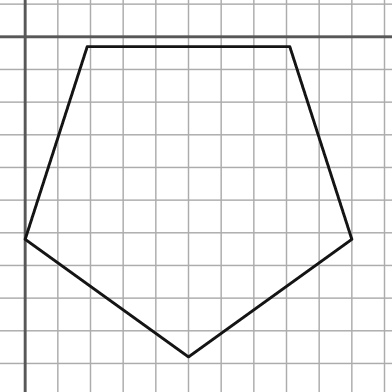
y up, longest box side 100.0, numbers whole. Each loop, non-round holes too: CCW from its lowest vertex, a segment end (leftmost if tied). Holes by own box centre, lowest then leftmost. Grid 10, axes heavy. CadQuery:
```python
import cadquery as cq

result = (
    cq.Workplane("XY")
    .moveTo(50.0, -98.0)
    .lineTo(100.0, -62.0)
    .lineTo(81.0, -3.0)
    .lineTo(19.0, -3.0)
    .lineTo(0.0, -62.0)
    .close()
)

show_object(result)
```